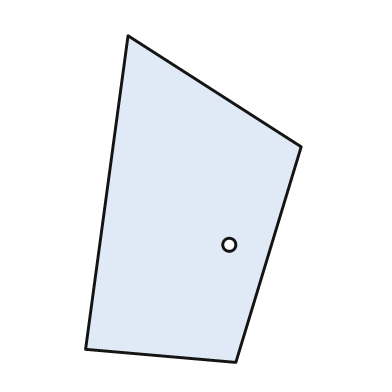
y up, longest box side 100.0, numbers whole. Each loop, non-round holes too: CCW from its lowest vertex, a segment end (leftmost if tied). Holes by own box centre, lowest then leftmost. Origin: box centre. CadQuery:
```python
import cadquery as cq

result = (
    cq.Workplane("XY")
    .moveTo(13.0, -50.0)
    .lineTo(33.0, 16.0)
    .lineTo(-20.0, 50.0)
    .lineTo(-33.0, -46.0)
    .close()
    .moveTo(11.0, -14.0)
    .circle(2.0)
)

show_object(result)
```